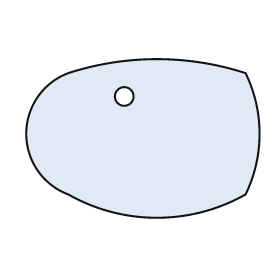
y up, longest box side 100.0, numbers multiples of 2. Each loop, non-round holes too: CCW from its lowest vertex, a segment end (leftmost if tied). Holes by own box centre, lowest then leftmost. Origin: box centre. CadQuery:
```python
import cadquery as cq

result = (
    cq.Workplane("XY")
    .moveTo(-32.0, -24.0)
    .threePointArc((6.0, -34.0), (44.0, -24.0))
    .threePointArc((50.0, 2.0), (44.0, 28.0))
    .threePointArc((6.0, 34.0), (-32.0, 28.0))
    .threePointArc((-50.0, 2.0), (-32.0, -24.0))
    .close()
    .moveTo(-8.0, 18.0)
    .circle(4.0)
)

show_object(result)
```